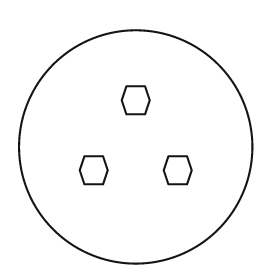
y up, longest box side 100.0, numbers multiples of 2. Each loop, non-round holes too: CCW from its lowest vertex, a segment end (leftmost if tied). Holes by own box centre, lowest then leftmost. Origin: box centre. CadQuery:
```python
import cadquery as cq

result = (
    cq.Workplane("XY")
    .moveTo(0.0, 0.0)
    .circle(50.0)
    .moveTo(-22.0, -16.0)
    .lineTo(-14.0, -16.0)
    .lineTo(-12.0, -10.0)
    .lineTo(-14.0, -4.0)
    .lineTo(-22.0, -4.0)
    .lineTo(-24.0, -10.0)
    .close()
    .moveTo(14.0, -16.0)
    .lineTo(22.0, -16.0)
    .lineTo(24.0, -10.0)
    .lineTo(22.0, -4.0)
    .lineTo(14.0, -4.0)
    .lineTo(12.0, -10.0)
    .close()
    .moveTo(-4.0, 14.0)
    .lineTo(4.0, 14.0)
    .lineTo(6.0, 20.0)
    .lineTo(4.0, 26.0)
    .lineTo(-4.0, 26.0)
    .lineTo(-6.0, 20.0)
    .close()
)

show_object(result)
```